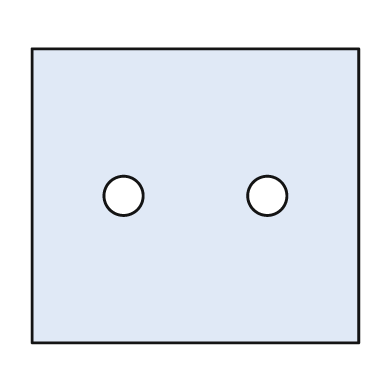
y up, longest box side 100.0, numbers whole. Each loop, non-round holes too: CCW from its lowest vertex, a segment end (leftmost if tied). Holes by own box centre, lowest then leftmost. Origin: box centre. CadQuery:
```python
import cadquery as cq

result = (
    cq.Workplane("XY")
    .moveTo(-50.0, -45.0)
    .lineTo(50.0, -45.0)
    .lineTo(50.0, 45.0)
    .lineTo(-50.0, 45.0)
    .close()
    .moveTo(-22.0, 0.0)
    .circle(6.0)
    .moveTo(22.0, 0.0)
    .circle(6.0)
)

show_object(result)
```